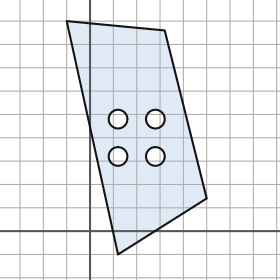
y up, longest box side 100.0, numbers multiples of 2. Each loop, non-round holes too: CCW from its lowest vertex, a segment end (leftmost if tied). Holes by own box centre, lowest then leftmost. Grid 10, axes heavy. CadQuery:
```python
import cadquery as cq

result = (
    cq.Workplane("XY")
    .moveTo(12.0, -10.0)
    .lineTo(50.0, 14.0)
    .lineTo(32.0, 86.0)
    .lineTo(-10.0, 90.0)
    .close()
    .moveTo(12.0, 32.0)
    .circle(4.0)
    .moveTo(28.0, 32.0)
    .circle(4.0)
    .moveTo(12.0, 48.0)
    .circle(4.0)
    .moveTo(28.0, 48.0)
    .circle(4.0)
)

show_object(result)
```